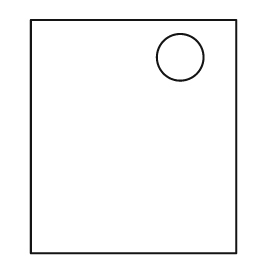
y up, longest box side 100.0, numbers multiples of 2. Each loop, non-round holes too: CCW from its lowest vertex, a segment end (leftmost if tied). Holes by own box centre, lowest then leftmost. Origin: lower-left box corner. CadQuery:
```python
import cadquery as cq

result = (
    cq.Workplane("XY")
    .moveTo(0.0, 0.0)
    .lineTo(88.0, 0.0)
    .lineTo(88.0, 100.0)
    .lineTo(0.0, 100.0)
    .close()
    .moveTo(64.0, 84.0)
    .circle(10.0)
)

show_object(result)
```